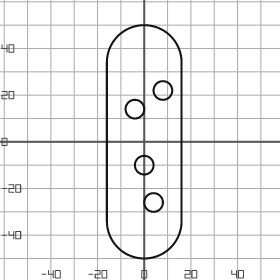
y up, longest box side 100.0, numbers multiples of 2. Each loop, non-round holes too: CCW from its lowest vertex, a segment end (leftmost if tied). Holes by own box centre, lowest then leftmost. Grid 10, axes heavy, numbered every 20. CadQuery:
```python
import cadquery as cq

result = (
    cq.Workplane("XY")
    .moveTo(-16.0, -34.0)
    .threePointArc((0.0, -50.0), (16.0, -34.0))
    .lineTo(16.0, 34.0)
    .threePointArc((0.0, 50.0), (-16.0, 34.0))
    .close()
    .moveTo(4.0, -26.0)
    .circle(4.0)
    .moveTo(0.0, -10.0)
    .circle(4.0)
    .moveTo(-4.0, 14.0)
    .circle(4.0)
    .moveTo(8.0, 22.0)
    .circle(4.0)
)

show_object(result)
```